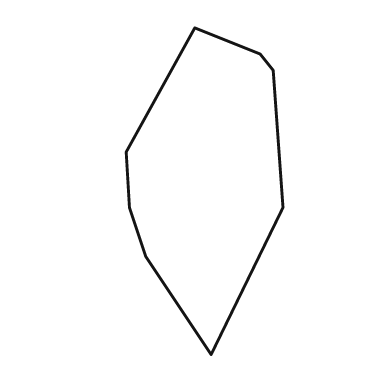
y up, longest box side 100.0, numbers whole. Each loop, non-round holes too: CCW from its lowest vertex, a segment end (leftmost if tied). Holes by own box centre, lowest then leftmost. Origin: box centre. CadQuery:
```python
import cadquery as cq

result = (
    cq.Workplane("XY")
    .moveTo(2.0, -50.0)
    .lineTo(24.0, -5.0)
    .lineTo(21.0, 37.0)
    .lineTo(17.0, 42.0)
    .lineTo(-3.0, 50.0)
    .lineTo(-24.0, 12.0)
    .lineTo(-23.0, -5.0)
    .lineTo(-18.0, -20.0)
    .close()
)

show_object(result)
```